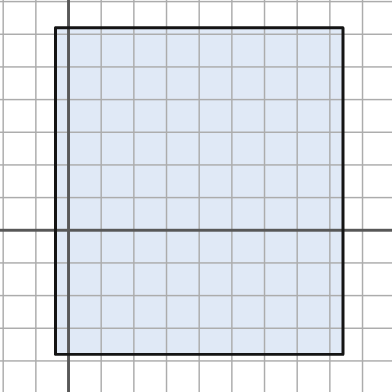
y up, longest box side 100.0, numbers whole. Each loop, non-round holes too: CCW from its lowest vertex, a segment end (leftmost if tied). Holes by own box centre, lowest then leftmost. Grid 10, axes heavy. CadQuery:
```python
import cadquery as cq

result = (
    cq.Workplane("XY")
    .moveTo(-4.0, -38.0)
    .lineTo(84.0, -38.0)
    .lineTo(84.0, 62.0)
    .lineTo(-4.0, 62.0)
    .close()
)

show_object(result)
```